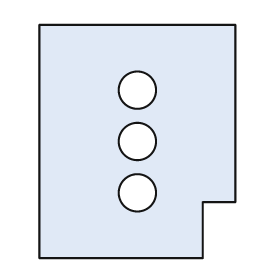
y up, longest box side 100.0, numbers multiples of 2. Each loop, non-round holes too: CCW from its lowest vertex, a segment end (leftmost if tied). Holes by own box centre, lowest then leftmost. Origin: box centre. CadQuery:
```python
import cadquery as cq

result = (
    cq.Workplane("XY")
    .moveTo(-42.0, -50.0)
    .lineTo(28.0, -50.0)
    .lineTo(28.0, -26.0)
    .lineTo(42.0, -26.0)
    .lineTo(42.0, 50.0)
    .lineTo(-42.0, 50.0)
    .close()
    .moveTo(0.0, -22.0)
    .circle(8.0)
    .moveTo(0.0, 0.0)
    .circle(8.0)
    .moveTo(0.0, 22.0)
    .circle(8.0)
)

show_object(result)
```